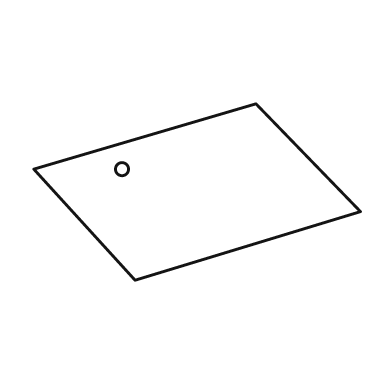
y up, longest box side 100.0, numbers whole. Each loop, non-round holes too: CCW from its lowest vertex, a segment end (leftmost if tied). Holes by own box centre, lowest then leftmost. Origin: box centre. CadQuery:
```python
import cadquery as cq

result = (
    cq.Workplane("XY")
    .moveTo(-19.0, -27.0)
    .lineTo(50.0, -6.0)
    .lineTo(18.0, 27.0)
    .lineTo(-50.0, 7.0)
    .close()
    .moveTo(-23.0, 7.0)
    .circle(2.0)
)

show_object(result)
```